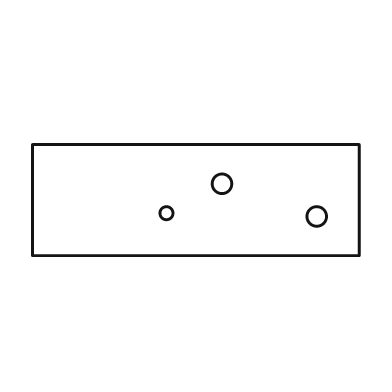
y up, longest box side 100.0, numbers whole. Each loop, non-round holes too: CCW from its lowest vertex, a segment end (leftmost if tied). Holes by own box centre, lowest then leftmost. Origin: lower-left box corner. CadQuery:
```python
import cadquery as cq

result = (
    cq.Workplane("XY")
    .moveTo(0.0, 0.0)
    .lineTo(100.0, 0.0)
    .lineTo(100.0, 34.0)
    .lineTo(0.0, 34.0)
    .close()
    .moveTo(87.0, 12.0)
    .circle(3.0)
    .moveTo(41.0, 13.0)
    .circle(2.0)
    .moveTo(58.0, 22.0)
    .circle(3.0)
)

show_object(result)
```